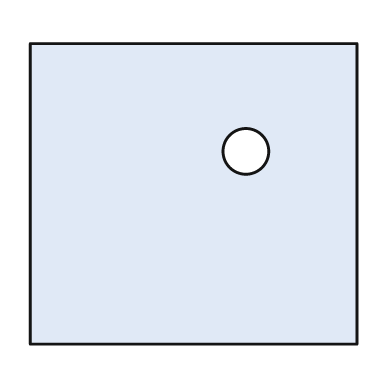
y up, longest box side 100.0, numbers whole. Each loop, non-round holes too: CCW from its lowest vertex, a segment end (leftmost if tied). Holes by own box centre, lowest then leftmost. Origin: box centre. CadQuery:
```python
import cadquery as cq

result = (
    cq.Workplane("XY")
    .moveTo(-50.0, -46.0)
    .lineTo(50.0, -46.0)
    .lineTo(50.0, 46.0)
    .lineTo(-50.0, 46.0)
    .close()
    .moveTo(16.0, 13.0)
    .circle(7.0)
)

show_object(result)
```